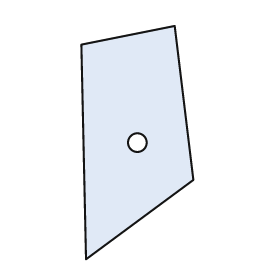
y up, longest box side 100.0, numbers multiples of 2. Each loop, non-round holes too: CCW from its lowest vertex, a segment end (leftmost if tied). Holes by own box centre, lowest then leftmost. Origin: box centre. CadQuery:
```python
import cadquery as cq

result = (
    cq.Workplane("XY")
    .moveTo(-22.0, -50.0)
    .lineTo(24.0, -16.0)
    .lineTo(16.0, 50.0)
    .lineTo(-24.0, 42.0)
    .close()
    .moveTo(0.0, 0.0)
    .circle(4.0)
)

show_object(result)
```